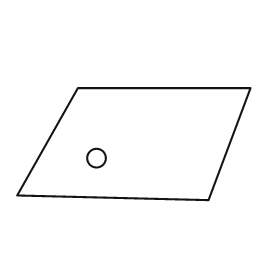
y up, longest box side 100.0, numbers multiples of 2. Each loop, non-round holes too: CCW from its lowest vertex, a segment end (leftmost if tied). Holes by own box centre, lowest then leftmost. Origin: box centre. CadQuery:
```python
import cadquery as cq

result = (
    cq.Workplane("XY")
    .moveTo(32.0, -24.0)
    .lineTo(50.0, 24.0)
    .lineTo(-24.0, 24.0)
    .lineTo(-50.0, -22.0)
    .close()
    .moveTo(-16.0, -6.0)
    .circle(4.0)
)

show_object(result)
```